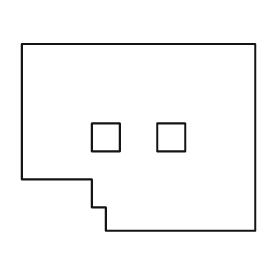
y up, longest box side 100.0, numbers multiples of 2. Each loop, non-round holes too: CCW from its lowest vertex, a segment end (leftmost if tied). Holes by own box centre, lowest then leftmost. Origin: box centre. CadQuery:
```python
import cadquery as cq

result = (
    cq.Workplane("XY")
    .moveTo(-14.0, -40.0)
    .lineTo(50.0, -40.0)
    .lineTo(50.0, 40.0)
    .lineTo(-50.0, 40.0)
    .lineTo(-50.0, -18.0)
    .lineTo(-20.0, -18.0)
    .lineTo(-20.0, -30.0)
    .lineTo(-14.0, -30.0)
    .close()
    .moveTo(-20.0, -6.0)
    .lineTo(-8.0, -6.0)
    .lineTo(-8.0, 6.0)
    .lineTo(-20.0, 6.0)
    .close()
    .moveTo(8.0, -6.0)
    .lineTo(20.0, -6.0)
    .lineTo(20.0, 6.0)
    .lineTo(8.0, 6.0)
    .close()
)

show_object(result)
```